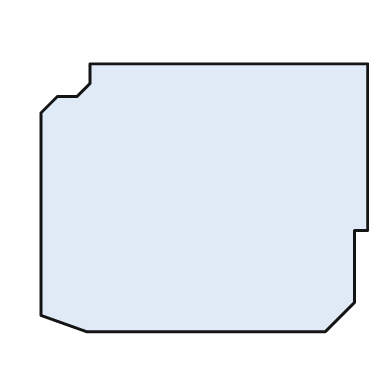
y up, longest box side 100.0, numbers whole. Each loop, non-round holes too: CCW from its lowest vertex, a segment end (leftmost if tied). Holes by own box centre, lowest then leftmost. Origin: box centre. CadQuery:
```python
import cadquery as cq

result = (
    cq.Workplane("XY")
    .moveTo(-36.0, -41.0)
    .lineTo(37.0, -41.0)
    .lineTo(46.0, -32.0)
    .lineTo(46.0, -10.0)
    .lineTo(50.0, -10.0)
    .lineTo(50.0, 41.0)
    .lineTo(-35.0, 41.0)
    .lineTo(-35.0, 35.0)
    .lineTo(-39.0, 31.0)
    .lineTo(-45.0, 31.0)
    .lineTo(-50.0, 26.0)
    .lineTo(-50.0, -36.0)
    .close()
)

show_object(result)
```